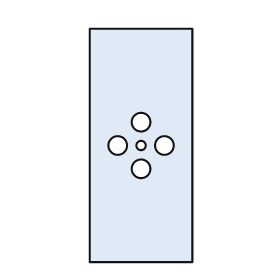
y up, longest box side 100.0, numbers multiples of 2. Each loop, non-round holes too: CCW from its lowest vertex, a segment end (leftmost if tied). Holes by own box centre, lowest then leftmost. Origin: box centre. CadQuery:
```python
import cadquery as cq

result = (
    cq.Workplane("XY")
    .moveTo(-22.0, -50.0)
    .lineTo(22.0, -50.0)
    .lineTo(22.0, 50.0)
    .lineTo(-22.0, 50.0)
    .close()
    .moveTo(0.0, -10.0)
    .circle(4.0)
    .moveTo(-10.0, 0.0)
    .circle(4.0)
    .moveTo(0.0, 0.0)
    .circle(2.0)
    .moveTo(10.0, 0.0)
    .circle(4.0)
    .moveTo(0.0, 10.0)
    .circle(4.0)
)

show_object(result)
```